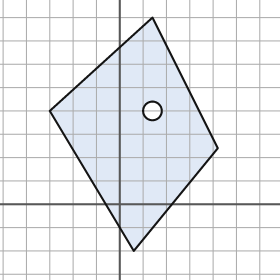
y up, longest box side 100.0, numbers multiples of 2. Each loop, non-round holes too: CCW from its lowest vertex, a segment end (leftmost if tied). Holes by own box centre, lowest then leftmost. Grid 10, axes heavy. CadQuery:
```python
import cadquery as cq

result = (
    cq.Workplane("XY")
    .moveTo(6.0, -20.0)
    .lineTo(42.0, 24.0)
    .lineTo(14.0, 80.0)
    .lineTo(-30.0, 40.0)
    .close()
    .moveTo(14.0, 40.0)
    .circle(4.0)
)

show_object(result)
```